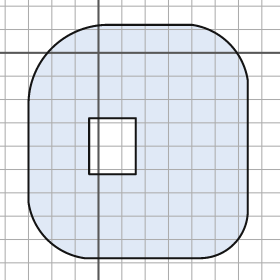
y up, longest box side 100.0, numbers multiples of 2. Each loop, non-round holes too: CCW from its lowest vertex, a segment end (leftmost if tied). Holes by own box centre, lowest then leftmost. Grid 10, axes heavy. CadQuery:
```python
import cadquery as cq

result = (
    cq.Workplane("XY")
    .moveTo(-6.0, -88.0)
    .lineTo(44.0, -88.0)
    .threePointArc((58.0, -82.0), (64.0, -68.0))
    .lineTo(64.0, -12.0)
    .threePointArc((56.0, 4.0), (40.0, 12.0))
    .lineTo(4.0, 12.0)
    .threePointArc((-20.0, 2.0), (-30.0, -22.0))
    .lineTo(-30.0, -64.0)
    .threePointArc((-22.0, -80.0), (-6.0, -88.0))
    .close()
    .moveTo(-4.0, -52.0)
    .lineTo(16.0, -52.0)
    .lineTo(16.0, -28.0)
    .lineTo(-4.0, -28.0)
    .close()
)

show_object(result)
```